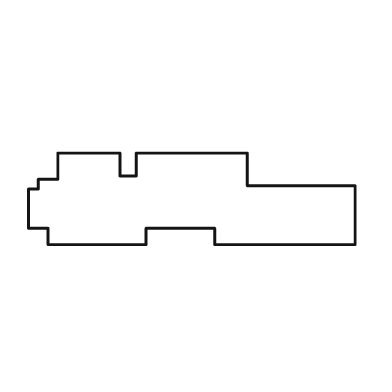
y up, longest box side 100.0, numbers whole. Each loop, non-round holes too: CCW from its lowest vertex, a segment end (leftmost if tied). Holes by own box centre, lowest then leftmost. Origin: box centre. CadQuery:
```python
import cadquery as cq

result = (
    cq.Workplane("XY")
    .moveTo(-44.0, -14.0)
    .lineTo(-14.0, -14.0)
    .lineTo(-14.0, -9.0)
    .lineTo(7.0, -9.0)
    .lineTo(7.0, -14.0)
    .lineTo(50.0, -14.0)
    .lineTo(50.0, 4.0)
    .lineTo(17.0, 4.0)
    .lineTo(17.0, 14.0)
    .lineTo(-17.0, 14.0)
    .lineTo(-17.0, 7.0)
    .lineTo(-22.0, 7.0)
    .lineTo(-22.0, 14.0)
    .lineTo(-41.0, 14.0)
    .lineTo(-41.0, 6.0)
    .lineTo(-47.0, 6.0)
    .lineTo(-47.0, 3.0)
    .lineTo(-50.0, 3.0)
    .lineTo(-50.0, -9.0)
    .lineTo(-44.0, -9.0)
    .close()
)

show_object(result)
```